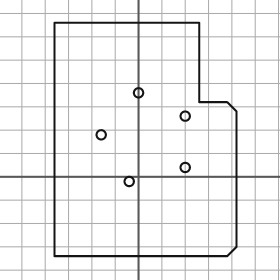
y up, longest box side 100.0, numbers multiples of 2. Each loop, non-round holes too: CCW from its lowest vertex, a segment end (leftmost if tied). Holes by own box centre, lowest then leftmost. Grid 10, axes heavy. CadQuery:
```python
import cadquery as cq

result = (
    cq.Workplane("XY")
    .moveTo(-36.0, -34.0)
    .lineTo(38.0, -34.0)
    .lineTo(42.0, -30.0)
    .lineTo(42.0, 28.0)
    .lineTo(38.0, 32.0)
    .lineTo(26.0, 32.0)
    .lineTo(26.0, 66.0)
    .lineTo(-36.0, 66.0)
    .close()
    .moveTo(-4.0, -2.0)
    .circle(2.0)
    .moveTo(20.0, 4.0)
    .circle(2.0)
    .moveTo(-16.0, 18.0)
    .circle(2.0)
    .moveTo(20.0, 26.0)
    .circle(2.0)
    .moveTo(0.0, 36.0)
    .circle(2.0)
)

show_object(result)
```